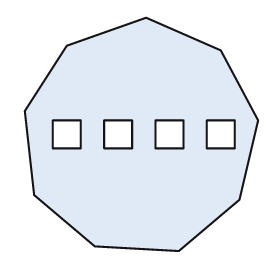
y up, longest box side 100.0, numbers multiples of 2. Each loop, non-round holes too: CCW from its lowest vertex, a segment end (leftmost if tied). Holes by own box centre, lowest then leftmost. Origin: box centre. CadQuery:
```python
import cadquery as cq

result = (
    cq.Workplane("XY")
    .moveTo(16.0, -50.0)
    .lineTo(42.0, -28.0)
    .lineTo(50.0, 6.0)
    .lineTo(34.0, 36.0)
    .lineTo(2.0, 50.0)
    .lineTo(-32.0, 38.0)
    .lineTo(-50.0, 10.0)
    .lineTo(-46.0, -26.0)
    .lineTo(-20.0, -48.0)
    .close()
    .moveTo(-38.0, -6.0)
    .lineTo(-26.0, -6.0)
    .lineTo(-26.0, 6.0)
    .lineTo(-38.0, 6.0)
    .close()
    .moveTo(-16.0, -6.0)
    .lineTo(-4.0, -6.0)
    .lineTo(-4.0, 6.0)
    .lineTo(-16.0, 6.0)
    .close()
    .moveTo(6.0, -6.0)
    .lineTo(18.0, -6.0)
    .lineTo(18.0, 6.0)
    .lineTo(6.0, 6.0)
    .close()
    .moveTo(28.0, -6.0)
    .lineTo(40.0, -6.0)
    .lineTo(40.0, 6.0)
    .lineTo(28.0, 6.0)
    .close()
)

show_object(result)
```